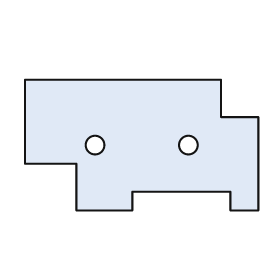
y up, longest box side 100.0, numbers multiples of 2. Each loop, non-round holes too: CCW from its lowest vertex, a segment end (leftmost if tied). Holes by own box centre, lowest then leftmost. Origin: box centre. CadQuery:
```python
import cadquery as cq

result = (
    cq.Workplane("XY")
    .moveTo(-28.0, -28.0)
    .lineTo(-4.0, -28.0)
    .lineTo(-4.0, -20.0)
    .lineTo(38.0, -20.0)
    .lineTo(38.0, -28.0)
    .lineTo(50.0, -28.0)
    .lineTo(50.0, 12.0)
    .lineTo(34.0, 12.0)
    .lineTo(34.0, 28.0)
    .lineTo(-50.0, 28.0)
    .lineTo(-50.0, -8.0)
    .lineTo(-28.0, -8.0)
    .close()
    .moveTo(-20.0, 0.0)
    .circle(4.0)
    .moveTo(20.0, 0.0)
    .circle(4.0)
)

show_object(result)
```